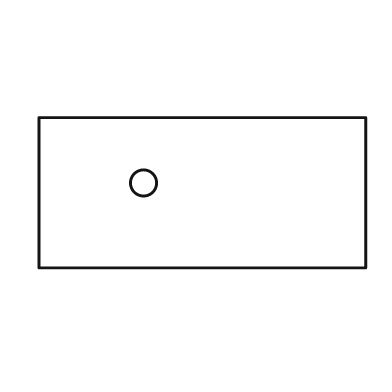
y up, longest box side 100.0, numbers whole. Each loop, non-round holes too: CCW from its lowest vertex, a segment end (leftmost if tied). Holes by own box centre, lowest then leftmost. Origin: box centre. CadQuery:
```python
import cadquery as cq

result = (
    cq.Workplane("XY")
    .moveTo(-50.0, -23.0)
    .lineTo(50.0, -23.0)
    .lineTo(50.0, 23.0)
    .lineTo(-50.0, 23.0)
    .close()
    .moveTo(-18.0, 3.0)
    .circle(4.0)
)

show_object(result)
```